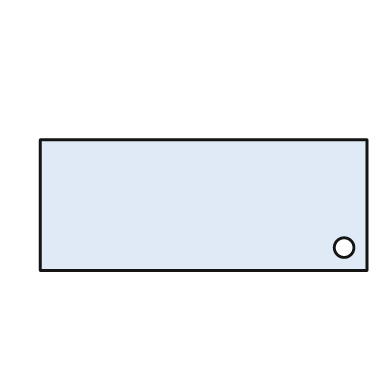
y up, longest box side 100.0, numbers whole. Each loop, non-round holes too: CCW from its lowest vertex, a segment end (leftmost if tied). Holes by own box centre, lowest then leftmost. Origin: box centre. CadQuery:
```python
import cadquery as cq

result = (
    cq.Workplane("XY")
    .moveTo(-50.0, -20.0)
    .lineTo(50.0, -20.0)
    .lineTo(50.0, 20.0)
    .lineTo(-50.0, 20.0)
    .close()
    .moveTo(43.0, -13.0)
    .circle(3.0)
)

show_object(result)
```